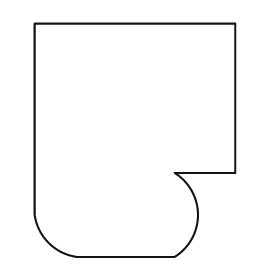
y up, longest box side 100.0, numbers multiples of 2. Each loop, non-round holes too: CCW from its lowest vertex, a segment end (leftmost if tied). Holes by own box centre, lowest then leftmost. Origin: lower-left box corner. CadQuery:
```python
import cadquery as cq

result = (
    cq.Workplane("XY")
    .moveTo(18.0, 0.0)
    .lineTo(60.0, 0.0)
    .threePointArc((70.0, 18.0), (60.0, 36.0))
    .lineTo(86.0, 36.0)
    .lineTo(86.0, 100.0)
    .lineTo(0.0, 100.0)
    .lineTo(0.0, 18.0)
    .threePointArc((6.0, 6.0), (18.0, 0.0))
    .close()
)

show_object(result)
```